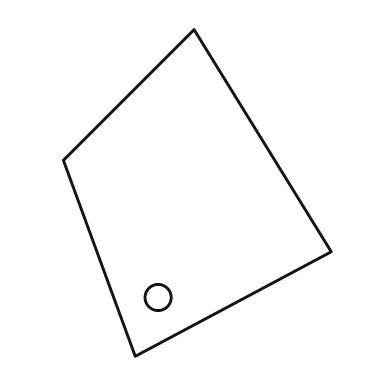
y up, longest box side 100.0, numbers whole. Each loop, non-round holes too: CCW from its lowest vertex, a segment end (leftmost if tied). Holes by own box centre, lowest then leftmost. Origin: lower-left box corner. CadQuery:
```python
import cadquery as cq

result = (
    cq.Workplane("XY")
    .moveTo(22.0, 0.0)
    .lineTo(82.0, 32.0)
    .lineTo(40.0, 100.0)
    .lineTo(0.0, 60.0)
    .close()
    .moveTo(29.0, 18.0)
    .circle(4.0)
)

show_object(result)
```